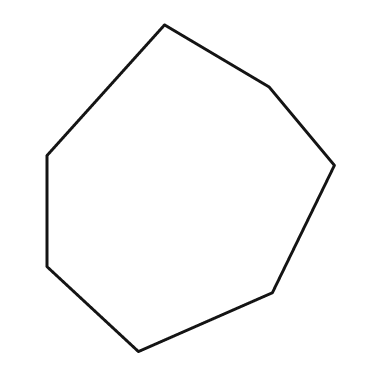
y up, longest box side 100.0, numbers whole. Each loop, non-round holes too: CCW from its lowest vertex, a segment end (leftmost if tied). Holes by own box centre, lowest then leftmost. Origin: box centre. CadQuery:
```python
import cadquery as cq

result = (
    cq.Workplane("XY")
    .moveTo(-16.0, -50.0)
    .lineTo(25.0, -32.0)
    .lineTo(44.0, 7.0)
    .lineTo(24.0, 31.0)
    .lineTo(-8.0, 50.0)
    .lineTo(-44.0, 10.0)
    .lineTo(-44.0, -24.0)
    .close()
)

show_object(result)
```